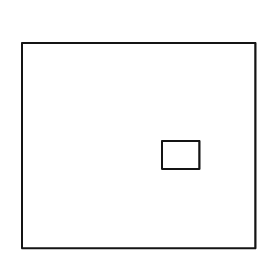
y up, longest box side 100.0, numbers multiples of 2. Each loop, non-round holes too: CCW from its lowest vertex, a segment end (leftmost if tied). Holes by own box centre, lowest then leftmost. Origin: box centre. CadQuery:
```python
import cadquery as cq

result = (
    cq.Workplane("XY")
    .moveTo(-50.0, -44.0)
    .lineTo(50.0, -44.0)
    .lineTo(50.0, 44.0)
    .lineTo(-50.0, 44.0)
    .close()
    .moveTo(10.0, -10.0)
    .lineTo(26.0, -10.0)
    .lineTo(26.0, 2.0)
    .lineTo(10.0, 2.0)
    .close()
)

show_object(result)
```